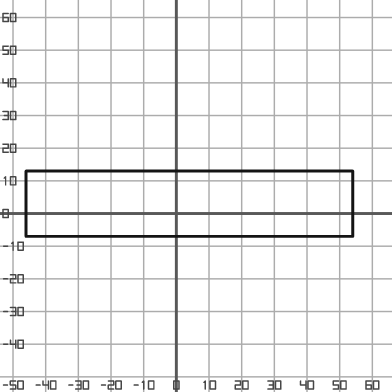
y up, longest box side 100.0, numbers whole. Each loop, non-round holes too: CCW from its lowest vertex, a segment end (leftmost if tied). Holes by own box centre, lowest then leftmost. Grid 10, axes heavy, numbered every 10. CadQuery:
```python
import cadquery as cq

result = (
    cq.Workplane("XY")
    .moveTo(-46.0, -7.0)
    .lineTo(54.0, -7.0)
    .lineTo(54.0, 13.0)
    .lineTo(-46.0, 13.0)
    .close()
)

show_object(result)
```